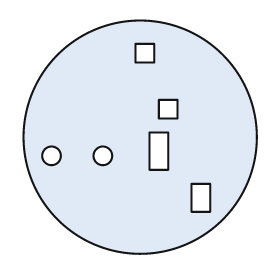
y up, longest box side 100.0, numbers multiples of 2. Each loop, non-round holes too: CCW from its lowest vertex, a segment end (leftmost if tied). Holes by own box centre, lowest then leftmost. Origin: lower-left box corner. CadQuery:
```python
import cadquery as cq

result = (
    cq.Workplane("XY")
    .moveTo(50.0, 50.0)
    .circle(50.0)
    .moveTo(72.0, 18.0)
    .lineTo(80.0, 18.0)
    .lineTo(80.0, 30.0)
    .lineTo(72.0, 30.0)
    .close()
    .moveTo(12.0, 42.0)
    .circle(4.0)
    .moveTo(34.0, 42.0)
    .circle(4.0)
    .moveTo(54.0, 36.0)
    .lineTo(62.0, 36.0)
    .lineTo(62.0, 52.0)
    .lineTo(54.0, 52.0)
    .close()
    .moveTo(58.0, 58.0)
    .lineTo(66.0, 58.0)
    .lineTo(66.0, 66.0)
    .lineTo(58.0, 66.0)
    .close()
    .moveTo(48.0, 82.0)
    .lineTo(56.0, 82.0)
    .lineTo(56.0, 90.0)
    .lineTo(48.0, 90.0)
    .close()
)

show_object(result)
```